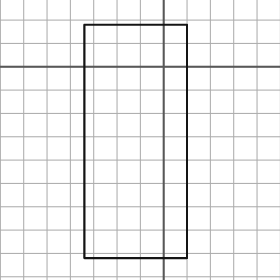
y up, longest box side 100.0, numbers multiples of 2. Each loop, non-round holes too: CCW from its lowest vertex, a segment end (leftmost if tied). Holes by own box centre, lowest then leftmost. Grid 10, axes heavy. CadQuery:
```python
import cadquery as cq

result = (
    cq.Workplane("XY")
    .moveTo(-34.0, -82.0)
    .lineTo(10.0, -82.0)
    .lineTo(10.0, 18.0)
    .lineTo(-34.0, 18.0)
    .close()
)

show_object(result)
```